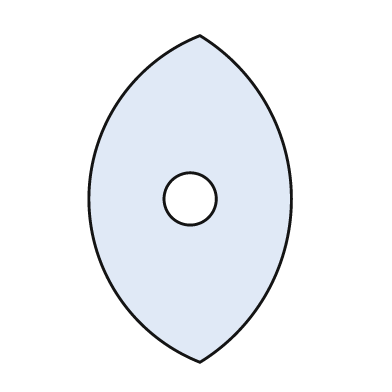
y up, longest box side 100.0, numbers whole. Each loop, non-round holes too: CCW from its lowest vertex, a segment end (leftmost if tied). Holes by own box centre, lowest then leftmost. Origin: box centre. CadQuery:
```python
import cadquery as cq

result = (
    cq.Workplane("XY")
    .moveTo(3.0, -50.0)
    .threePointArc((31.0, 0.0), (3.0, 50.0))
    .threePointArc((-31.0, 0.0), (3.0, -50.0))
    .close()
    .moveTo(0.0, 0.0)
    .circle(8.0)
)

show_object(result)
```